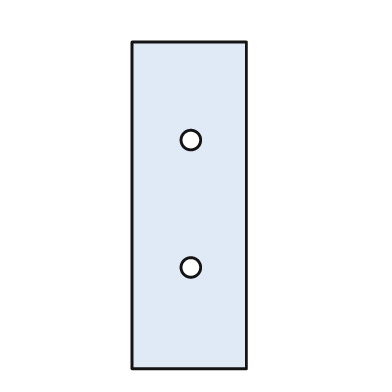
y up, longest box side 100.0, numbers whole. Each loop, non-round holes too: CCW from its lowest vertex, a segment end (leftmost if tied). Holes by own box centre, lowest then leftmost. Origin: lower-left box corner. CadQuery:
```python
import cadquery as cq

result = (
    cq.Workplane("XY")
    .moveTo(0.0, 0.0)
    .lineTo(35.0, 0.0)
    .lineTo(35.0, 100.0)
    .lineTo(0.0, 100.0)
    .close()
    .moveTo(18.0, 31.0)
    .circle(3.0)
    .moveTo(18.0, 70.0)
    .circle(3.0)
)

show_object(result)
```